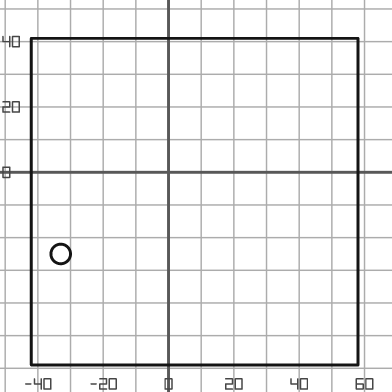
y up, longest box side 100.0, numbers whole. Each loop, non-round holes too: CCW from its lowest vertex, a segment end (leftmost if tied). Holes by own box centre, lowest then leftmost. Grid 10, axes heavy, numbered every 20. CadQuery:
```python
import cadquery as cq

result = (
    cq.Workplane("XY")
    .moveTo(-42.0, -59.0)
    .lineTo(58.0, -59.0)
    .lineTo(58.0, 41.0)
    .lineTo(-42.0, 41.0)
    .close()
    .moveTo(-33.0, -25.0)
    .circle(3.0)
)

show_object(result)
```